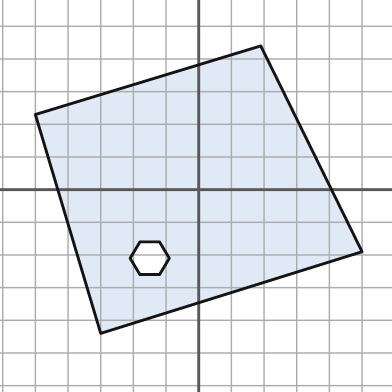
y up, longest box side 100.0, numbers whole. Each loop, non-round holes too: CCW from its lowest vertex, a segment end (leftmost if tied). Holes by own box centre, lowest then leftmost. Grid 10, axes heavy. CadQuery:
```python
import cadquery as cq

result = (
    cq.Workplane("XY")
    .moveTo(-30.0, -44.0)
    .lineTo(50.0, -19.0)
    .lineTo(19.0, 44.0)
    .lineTo(-50.0, 23.0)
    .close()
    .moveTo(-18.0, -26.0)
    .lineTo(-12.0, -26.0)
    .lineTo(-9.0, -21.0)
    .lineTo(-12.0, -16.0)
    .lineTo(-18.0, -16.0)
    .lineTo(-21.0, -21.0)
    .close()
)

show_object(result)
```